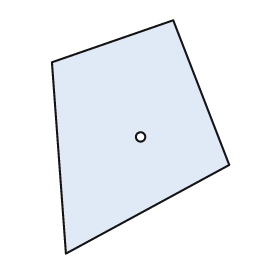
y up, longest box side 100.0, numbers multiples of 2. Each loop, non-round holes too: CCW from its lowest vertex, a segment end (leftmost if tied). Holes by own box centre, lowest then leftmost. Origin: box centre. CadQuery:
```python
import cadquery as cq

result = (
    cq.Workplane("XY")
    .moveTo(-32.0, -50.0)
    .lineTo(38.0, -12.0)
    .lineTo(14.0, 50.0)
    .lineTo(-38.0, 32.0)
    .close()
    .moveTo(0.0, 0.0)
    .circle(2.0)
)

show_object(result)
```